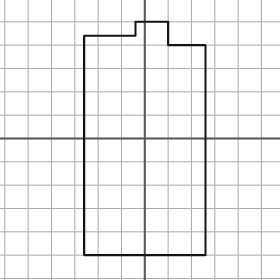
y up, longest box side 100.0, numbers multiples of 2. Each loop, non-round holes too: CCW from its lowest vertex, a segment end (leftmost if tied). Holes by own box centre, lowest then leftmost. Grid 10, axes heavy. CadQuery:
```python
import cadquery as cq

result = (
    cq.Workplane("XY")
    .moveTo(-26.0, -50.0)
    .lineTo(26.0, -50.0)
    .lineTo(26.0, 40.0)
    .lineTo(10.0, 40.0)
    .lineTo(10.0, 50.0)
    .lineTo(-4.0, 50.0)
    .lineTo(-4.0, 44.0)
    .lineTo(-26.0, 44.0)
    .close()
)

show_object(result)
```